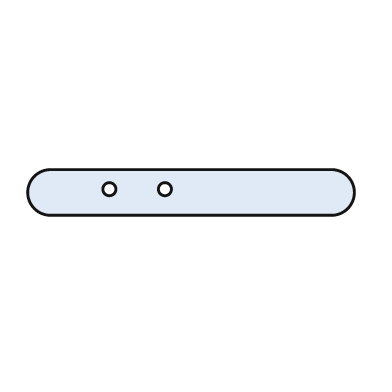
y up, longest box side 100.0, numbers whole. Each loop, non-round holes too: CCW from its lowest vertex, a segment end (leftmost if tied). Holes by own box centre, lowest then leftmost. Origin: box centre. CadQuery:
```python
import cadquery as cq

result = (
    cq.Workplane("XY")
    .moveTo(-43.0, -7.0)
    .lineTo(43.0, -7.0)
    .threePointArc((50.0, 0.0), (43.0, 7.0))
    .lineTo(-43.0, 7.0)
    .threePointArc((-50.0, 0.0), (-43.0, -7.0))
    .close()
    .moveTo(-25.0, 1.0)
    .circle(2.0)
    .moveTo(-8.0, 1.0)
    .circle(2.0)
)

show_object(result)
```